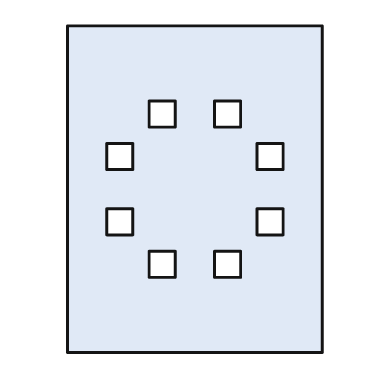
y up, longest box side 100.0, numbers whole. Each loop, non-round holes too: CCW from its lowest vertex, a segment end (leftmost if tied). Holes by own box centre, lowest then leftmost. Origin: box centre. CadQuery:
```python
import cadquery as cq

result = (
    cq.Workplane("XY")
    .moveTo(-39.0, -50.0)
    .lineTo(39.0, -50.0)
    .lineTo(39.0, 50.0)
    .lineTo(-39.0, 50.0)
    .close()
    .moveTo(-14.0, -27.0)
    .lineTo(-6.0, -27.0)
    .lineTo(-6.0, -19.0)
    .lineTo(-14.0, -19.0)
    .close()
    .moveTo(6.0, -27.0)
    .lineTo(14.0, -27.0)
    .lineTo(14.0, -19.0)
    .lineTo(6.0, -19.0)
    .close()
    .moveTo(-27.0, -14.0)
    .lineTo(-19.0, -14.0)
    .lineTo(-19.0, -6.0)
    .lineTo(-27.0, -6.0)
    .close()
    .moveTo(19.0, -14.0)
    .lineTo(27.0, -14.0)
    .lineTo(27.0, -6.0)
    .lineTo(19.0, -6.0)
    .close()
    .moveTo(-27.0, 6.0)
    .lineTo(-19.0, 6.0)
    .lineTo(-19.0, 14.0)
    .lineTo(-27.0, 14.0)
    .close()
    .moveTo(19.0, 6.0)
    .lineTo(27.0, 6.0)
    .lineTo(27.0, 14.0)
    .lineTo(19.0, 14.0)
    .close()
    .moveTo(-14.0, 19.0)
    .lineTo(-6.0, 19.0)
    .lineTo(-6.0, 27.0)
    .lineTo(-14.0, 27.0)
    .close()
    .moveTo(6.0, 19.0)
    .lineTo(14.0, 19.0)
    .lineTo(14.0, 27.0)
    .lineTo(6.0, 27.0)
    .close()
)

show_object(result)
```